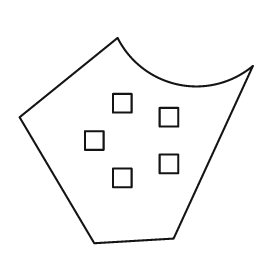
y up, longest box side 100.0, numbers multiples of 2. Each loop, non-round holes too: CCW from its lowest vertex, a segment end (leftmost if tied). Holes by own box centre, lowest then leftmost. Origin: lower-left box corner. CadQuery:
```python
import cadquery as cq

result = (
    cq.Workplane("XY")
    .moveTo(32.0, 0.0)
    .lineTo(66.0, 2.0)
    .lineTo(100.0, 76.0)
    .threePointArc((68.0, 68.0), (42.0, 88.0))
    .lineTo(0.0, 54.0)
    .close()
    .moveTo(40.0, 24.0)
    .lineTo(48.0, 24.0)
    .lineTo(48.0, 32.0)
    .lineTo(40.0, 32.0)
    .close()
    .moveTo(60.0, 30.0)
    .lineTo(68.0, 30.0)
    .lineTo(68.0, 38.0)
    .lineTo(60.0, 38.0)
    .close()
    .moveTo(28.0, 40.0)
    .lineTo(36.0, 40.0)
    .lineTo(36.0, 48.0)
    .lineTo(28.0, 48.0)
    .close()
    .moveTo(60.0, 50.0)
    .lineTo(68.0, 50.0)
    .lineTo(68.0, 58.0)
    .lineTo(60.0, 58.0)
    .close()
    .moveTo(40.0, 56.0)
    .lineTo(48.0, 56.0)
    .lineTo(48.0, 64.0)
    .lineTo(40.0, 64.0)
    .close()
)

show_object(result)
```